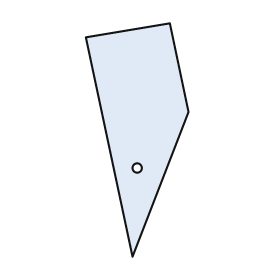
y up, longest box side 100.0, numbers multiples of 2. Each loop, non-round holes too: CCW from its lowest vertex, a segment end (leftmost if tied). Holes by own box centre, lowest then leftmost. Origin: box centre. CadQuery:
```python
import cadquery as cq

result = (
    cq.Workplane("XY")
    .moveTo(-2.0, -50.0)
    .lineTo(22.0, 12.0)
    .lineTo(14.0, 50.0)
    .lineTo(-22.0, 44.0)
    .close()
    .moveTo(0.0, -12.0)
    .circle(2.0)
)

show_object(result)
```